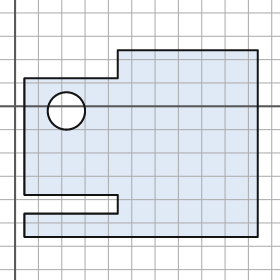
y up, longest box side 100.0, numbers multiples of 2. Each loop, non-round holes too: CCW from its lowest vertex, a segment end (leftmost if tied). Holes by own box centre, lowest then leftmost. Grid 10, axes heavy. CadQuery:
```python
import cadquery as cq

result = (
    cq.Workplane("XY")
    .moveTo(4.0, -56.0)
    .lineTo(104.0, -56.0)
    .lineTo(104.0, 24.0)
    .lineTo(44.0, 24.0)
    .lineTo(44.0, 12.0)
    .lineTo(4.0, 12.0)
    .lineTo(4.0, -38.0)
    .lineTo(44.0, -38.0)
    .lineTo(44.0, -46.0)
    .lineTo(4.0, -46.0)
    .close()
    .moveTo(22.0, -2.0)
    .circle(8.0)
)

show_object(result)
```